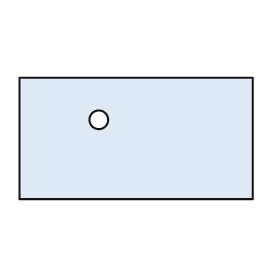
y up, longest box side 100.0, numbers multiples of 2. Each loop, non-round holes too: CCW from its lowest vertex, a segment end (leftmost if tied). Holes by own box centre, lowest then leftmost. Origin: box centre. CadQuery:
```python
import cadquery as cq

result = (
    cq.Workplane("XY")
    .moveTo(-50.0, -26.0)
    .lineTo(50.0, -26.0)
    .lineTo(50.0, 26.0)
    .lineTo(-50.0, 26.0)
    .close()
    .moveTo(-16.0, 8.0)
    .circle(4.0)
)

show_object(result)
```